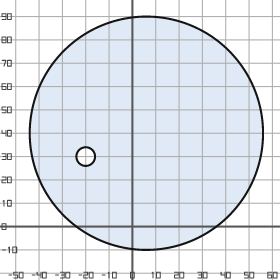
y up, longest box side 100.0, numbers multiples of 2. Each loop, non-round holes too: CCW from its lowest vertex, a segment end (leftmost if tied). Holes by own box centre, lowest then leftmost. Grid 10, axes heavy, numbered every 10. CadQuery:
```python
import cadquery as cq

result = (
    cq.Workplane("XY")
    .moveTo(6.0, 40.0)
    .circle(50.0)
    .moveTo(-20.0, 30.0)
    .circle(4.0)
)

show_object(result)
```